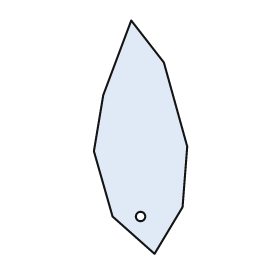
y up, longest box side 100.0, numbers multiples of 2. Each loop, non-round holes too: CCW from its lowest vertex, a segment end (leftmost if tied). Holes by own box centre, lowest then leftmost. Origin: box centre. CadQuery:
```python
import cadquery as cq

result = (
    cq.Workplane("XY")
    .moveTo(6.0, -50.0)
    .lineTo(18.0, -30.0)
    .lineTo(20.0, -4.0)
    .lineTo(10.0, 32.0)
    .lineTo(-4.0, 50.0)
    .lineTo(-16.0, 18.0)
    .lineTo(-20.0, -6.0)
    .lineTo(-12.0, -34.0)
    .close()
    .moveTo(0.0, -34.0)
    .circle(2.0)
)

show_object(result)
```